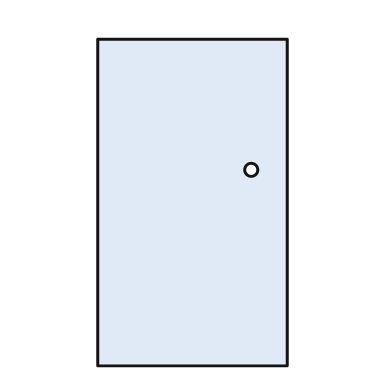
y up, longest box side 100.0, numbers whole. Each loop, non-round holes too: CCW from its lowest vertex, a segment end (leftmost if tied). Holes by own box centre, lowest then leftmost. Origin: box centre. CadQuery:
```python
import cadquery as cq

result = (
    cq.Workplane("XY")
    .moveTo(-29.0, -50.0)
    .lineTo(29.0, -50.0)
    .lineTo(29.0, 50.0)
    .lineTo(-29.0, 50.0)
    .close()
    .moveTo(18.0, 10.0)
    .circle(2.0)
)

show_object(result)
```